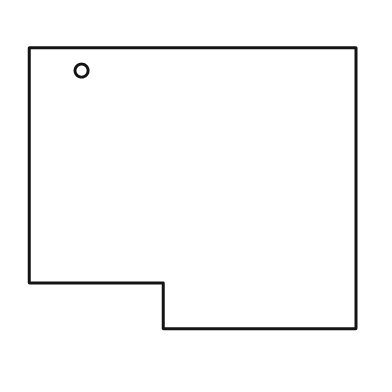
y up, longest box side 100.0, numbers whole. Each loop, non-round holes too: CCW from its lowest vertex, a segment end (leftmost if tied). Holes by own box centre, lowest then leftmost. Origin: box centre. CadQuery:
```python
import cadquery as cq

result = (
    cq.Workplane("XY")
    .moveTo(-9.0, -43.0)
    .lineTo(50.0, -43.0)
    .lineTo(50.0, 43.0)
    .lineTo(-50.0, 43.0)
    .lineTo(-50.0, -29.0)
    .lineTo(-9.0, -29.0)
    .close()
    .moveTo(-34.0, 36.0)
    .circle(2.0)
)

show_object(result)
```